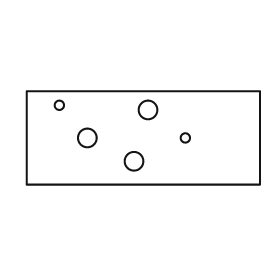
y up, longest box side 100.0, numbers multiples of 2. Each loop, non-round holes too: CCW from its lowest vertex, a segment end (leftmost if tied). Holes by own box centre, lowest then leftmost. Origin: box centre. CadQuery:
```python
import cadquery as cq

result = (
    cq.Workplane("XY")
    .moveTo(-50.0, -20.0)
    .lineTo(50.0, -20.0)
    .lineTo(50.0, 20.0)
    .lineTo(-50.0, 20.0)
    .close()
    .moveTo(-4.0, -10.0)
    .circle(4.0)
    .moveTo(-24.0, 0.0)
    .circle(4.0)
    .moveTo(18.0, 0.0)
    .circle(2.0)
    .moveTo(2.0, 12.0)
    .circle(4.0)
    .moveTo(-36.0, 14.0)
    .circle(2.0)
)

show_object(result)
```